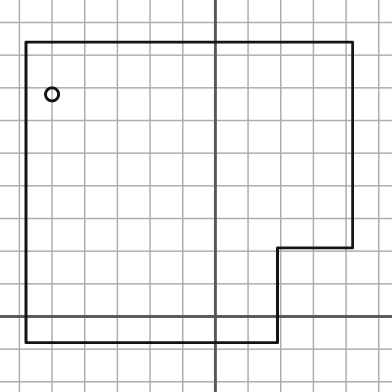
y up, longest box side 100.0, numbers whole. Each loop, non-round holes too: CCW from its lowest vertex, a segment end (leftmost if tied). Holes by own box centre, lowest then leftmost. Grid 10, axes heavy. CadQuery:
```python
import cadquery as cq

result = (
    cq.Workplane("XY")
    .moveTo(-58.0, -8.0)
    .lineTo(19.0, -8.0)
    .lineTo(19.0, 21.0)
    .lineTo(42.0, 21.0)
    .lineTo(42.0, 84.0)
    .lineTo(-58.0, 84.0)
    .close()
    .moveTo(-50.0, 68.0)
    .circle(2.0)
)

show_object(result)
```